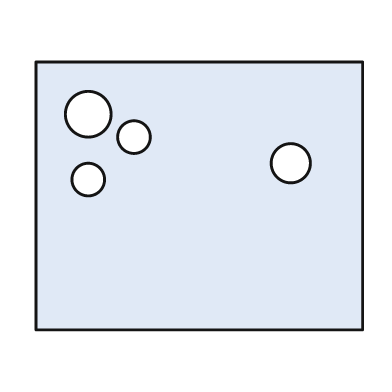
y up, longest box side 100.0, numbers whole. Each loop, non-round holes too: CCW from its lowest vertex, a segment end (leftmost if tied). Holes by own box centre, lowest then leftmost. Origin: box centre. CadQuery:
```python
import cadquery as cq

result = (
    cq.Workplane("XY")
    .moveTo(-50.0, -41.0)
    .lineTo(50.0, -41.0)
    .lineTo(50.0, 41.0)
    .lineTo(-50.0, 41.0)
    .close()
    .moveTo(-34.0, 5.0)
    .circle(5.0)
    .moveTo(28.0, 10.0)
    .circle(6.0)
    .moveTo(-20.0, 18.0)
    .circle(5.0)
    .moveTo(-34.0, 25.0)
    .circle(7.0)
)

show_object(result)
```